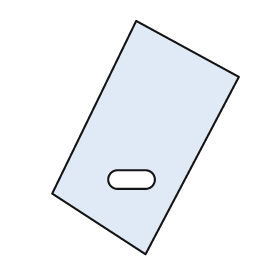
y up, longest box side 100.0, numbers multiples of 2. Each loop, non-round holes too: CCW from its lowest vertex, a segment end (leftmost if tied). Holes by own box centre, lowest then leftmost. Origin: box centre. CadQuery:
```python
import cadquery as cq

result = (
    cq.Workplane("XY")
    .moveTo(0.0, -50.0)
    .lineTo(40.0, 26.0)
    .lineTo(-4.0, 50.0)
    .lineTo(-40.0, -24.0)
    .close()
    .moveTo(-12.0, -22.0)
    .lineTo(0.0, -22.0)
    .threePointArc((4.0, -18.0), (0.0, -14.0))
    .lineTo(-12.0, -14.0)
    .threePointArc((-16.0, -18.0), (-12.0, -22.0))
    .close()
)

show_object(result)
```